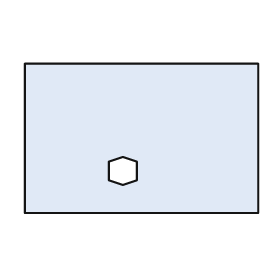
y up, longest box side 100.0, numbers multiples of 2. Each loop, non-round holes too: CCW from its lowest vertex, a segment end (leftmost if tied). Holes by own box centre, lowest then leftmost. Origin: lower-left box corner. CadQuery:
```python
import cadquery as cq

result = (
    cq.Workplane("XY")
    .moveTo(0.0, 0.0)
    .lineTo(100.0, 0.0)
    .lineTo(100.0, 64.0)
    .lineTo(0.0, 64.0)
    .close()
    .moveTo(42.0, 12.0)
    .lineTo(48.0, 14.0)
    .lineTo(48.0, 22.0)
    .lineTo(42.0, 24.0)
    .lineTo(36.0, 22.0)
    .lineTo(36.0, 14.0)
    .close()
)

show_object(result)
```